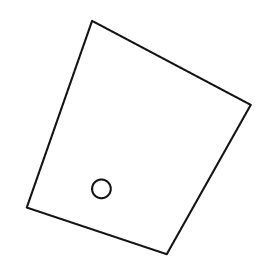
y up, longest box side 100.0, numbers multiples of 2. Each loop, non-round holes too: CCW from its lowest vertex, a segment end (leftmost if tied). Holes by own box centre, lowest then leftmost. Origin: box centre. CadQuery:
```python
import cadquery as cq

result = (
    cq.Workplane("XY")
    .moveTo(12.0, -50.0)
    .lineTo(48.0, 14.0)
    .lineTo(-20.0, 50.0)
    .lineTo(-48.0, -30.0)
    .close()
    .moveTo(-16.0, -22.0)
    .circle(4.0)
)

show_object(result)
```